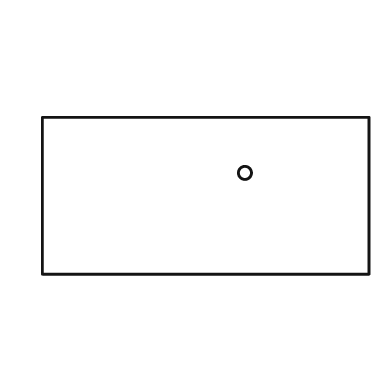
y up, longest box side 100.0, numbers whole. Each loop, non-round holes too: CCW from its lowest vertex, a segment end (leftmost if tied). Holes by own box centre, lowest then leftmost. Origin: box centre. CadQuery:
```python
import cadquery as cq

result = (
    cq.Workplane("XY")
    .moveTo(-50.0, -24.0)
    .lineTo(50.0, -24.0)
    .lineTo(50.0, 24.0)
    .lineTo(-50.0, 24.0)
    .close()
    .moveTo(12.0, 7.0)
    .circle(2.0)
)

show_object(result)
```